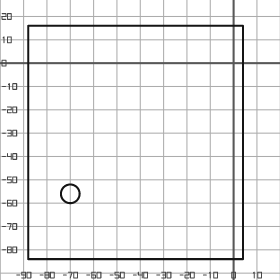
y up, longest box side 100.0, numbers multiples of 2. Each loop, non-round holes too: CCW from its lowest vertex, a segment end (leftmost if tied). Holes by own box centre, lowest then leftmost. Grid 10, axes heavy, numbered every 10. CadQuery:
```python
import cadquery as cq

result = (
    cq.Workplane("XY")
    .moveTo(-88.0, -84.0)
    .lineTo(4.0, -84.0)
    .lineTo(4.0, 16.0)
    .lineTo(-88.0, 16.0)
    .close()
    .moveTo(-70.0, -56.0)
    .circle(4.0)
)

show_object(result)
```